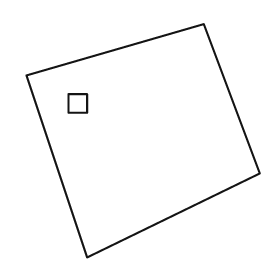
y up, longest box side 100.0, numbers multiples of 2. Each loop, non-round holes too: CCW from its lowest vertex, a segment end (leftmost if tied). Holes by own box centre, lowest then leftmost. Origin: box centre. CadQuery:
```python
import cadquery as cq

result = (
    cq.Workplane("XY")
    .moveTo(-24.0, -50.0)
    .lineTo(50.0, -14.0)
    .lineTo(26.0, 50.0)
    .lineTo(-50.0, 28.0)
    .close()
    .moveTo(-32.0, 12.0)
    .lineTo(-24.0, 12.0)
    .lineTo(-24.0, 20.0)
    .lineTo(-32.0, 20.0)
    .close()
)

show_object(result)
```